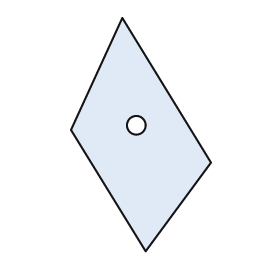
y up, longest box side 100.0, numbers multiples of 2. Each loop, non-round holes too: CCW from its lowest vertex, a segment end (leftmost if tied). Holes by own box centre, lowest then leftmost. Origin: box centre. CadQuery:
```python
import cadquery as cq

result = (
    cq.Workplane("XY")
    .moveTo(2.0, -50.0)
    .lineTo(30.0, -12.0)
    .lineTo(-8.0, 50.0)
    .lineTo(-30.0, 2.0)
    .close()
    .moveTo(-2.0, 4.0)
    .circle(4.0)
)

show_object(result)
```